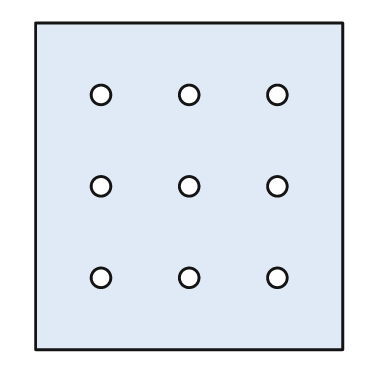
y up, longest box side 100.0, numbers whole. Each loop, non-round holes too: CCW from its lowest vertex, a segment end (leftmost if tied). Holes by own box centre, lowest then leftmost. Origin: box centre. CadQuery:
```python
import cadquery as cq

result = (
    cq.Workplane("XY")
    .moveTo(-47.0, -50.0)
    .lineTo(47.0, -50.0)
    .lineTo(47.0, 50.0)
    .lineTo(-47.0, 50.0)
    .close()
    .moveTo(-27.0, -28.0)
    .circle(3.0)
    .moveTo(0.0, -28.0)
    .circle(3.0)
    .moveTo(27.0, -28.0)
    .circle(3.0)
    .moveTo(-27.0, 0.0)
    .circle(3.0)
    .moveTo(0.0, 0.0)
    .circle(3.0)
    .moveTo(27.0, 0.0)
    .circle(3.0)
    .moveTo(-27.0, 28.0)
    .circle(3.0)
    .moveTo(0.0, 28.0)
    .circle(3.0)
    .moveTo(27.0, 28.0)
    .circle(3.0)
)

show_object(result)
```